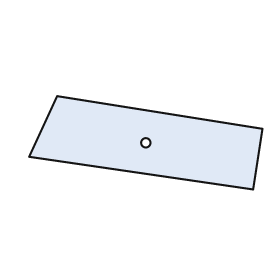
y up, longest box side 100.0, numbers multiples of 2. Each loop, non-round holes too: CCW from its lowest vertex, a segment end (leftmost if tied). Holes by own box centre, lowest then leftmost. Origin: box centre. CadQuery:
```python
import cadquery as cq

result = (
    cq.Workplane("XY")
    .moveTo(46.0, -20.0)
    .lineTo(50.0, 6.0)
    .lineTo(-38.0, 20.0)
    .lineTo(-50.0, -6.0)
    .close()
    .moveTo(0.0, 0.0)
    .circle(2.0)
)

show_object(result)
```